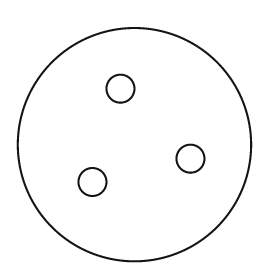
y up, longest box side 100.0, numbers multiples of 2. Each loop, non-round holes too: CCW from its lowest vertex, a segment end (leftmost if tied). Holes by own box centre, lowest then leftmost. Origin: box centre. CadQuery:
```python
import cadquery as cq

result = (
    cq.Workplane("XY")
    .moveTo(0.0, 0.0)
    .circle(50.0)
    .moveTo(-18.0, -16.0)
    .circle(6.0)
    .moveTo(24.0, -6.0)
    .circle(6.0)
    .moveTo(-6.0, 24.0)
    .circle(6.0)
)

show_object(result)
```